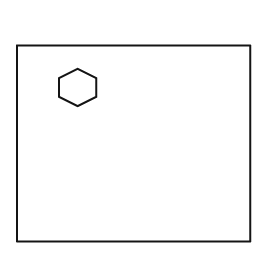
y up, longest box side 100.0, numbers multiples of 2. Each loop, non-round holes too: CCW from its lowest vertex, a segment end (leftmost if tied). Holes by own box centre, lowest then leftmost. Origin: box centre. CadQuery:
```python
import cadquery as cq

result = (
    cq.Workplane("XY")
    .moveTo(-50.0, -42.0)
    .lineTo(50.0, -42.0)
    .lineTo(50.0, 42.0)
    .lineTo(-50.0, 42.0)
    .close()
    .moveTo(-24.0, 16.0)
    .lineTo(-16.0, 20.0)
    .lineTo(-16.0, 28.0)
    .lineTo(-24.0, 32.0)
    .lineTo(-32.0, 28.0)
    .lineTo(-32.0, 20.0)
    .close()
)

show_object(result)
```